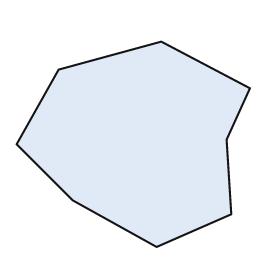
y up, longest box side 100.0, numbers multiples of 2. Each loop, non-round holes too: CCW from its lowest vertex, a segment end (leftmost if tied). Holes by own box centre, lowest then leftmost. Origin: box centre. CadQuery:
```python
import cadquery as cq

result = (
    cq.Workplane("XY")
    .moveTo(10.0, -44.0)
    .lineTo(42.0, -30.0)
    .lineTo(40.0, 2.0)
    .lineTo(50.0, 24.0)
    .lineTo(12.0, 44.0)
    .lineTo(-32.0, 32.0)
    .lineTo(-50.0, 0.0)
    .lineTo(-26.0, -24.0)
    .close()
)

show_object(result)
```